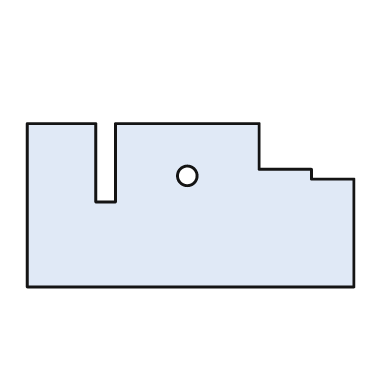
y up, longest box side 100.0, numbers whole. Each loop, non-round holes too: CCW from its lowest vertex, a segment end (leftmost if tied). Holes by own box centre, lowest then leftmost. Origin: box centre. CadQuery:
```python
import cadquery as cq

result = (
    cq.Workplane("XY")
    .moveTo(-50.0, -25.0)
    .lineTo(50.0, -25.0)
    .lineTo(50.0, 8.0)
    .lineTo(37.0, 8.0)
    .lineTo(37.0, 11.0)
    .lineTo(21.0, 11.0)
    .lineTo(21.0, 25.0)
    .lineTo(-23.0, 25.0)
    .lineTo(-23.0, 1.0)
    .lineTo(-29.0, 1.0)
    .lineTo(-29.0, 25.0)
    .lineTo(-50.0, 25.0)
    .close()
    .moveTo(-1.0, 9.0)
    .circle(3.0)
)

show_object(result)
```